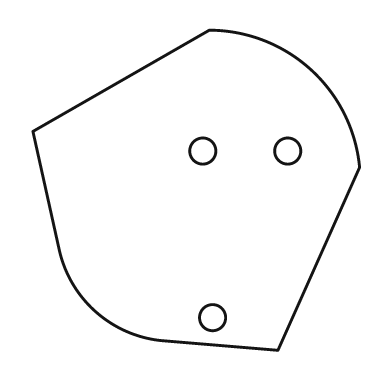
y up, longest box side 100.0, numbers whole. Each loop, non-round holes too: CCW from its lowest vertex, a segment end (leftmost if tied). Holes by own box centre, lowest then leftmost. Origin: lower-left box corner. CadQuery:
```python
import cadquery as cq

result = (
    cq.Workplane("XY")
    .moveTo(75.0, 0.0)
    .lineTo(100.0, 56.0)
    .threePointArc((85.0, 86.0), (54.0, 98.0))
    .lineTo(0.0, 67.0)
    .lineTo(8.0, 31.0)
    .threePointArc((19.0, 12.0), (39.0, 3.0))
    .close()
    .moveTo(55.0, 10.0)
    .circle(4.0)
    .moveTo(52.0, 61.0)
    .circle(4.0)
    .moveTo(78.0, 61.0)
    .circle(4.0)
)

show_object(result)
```